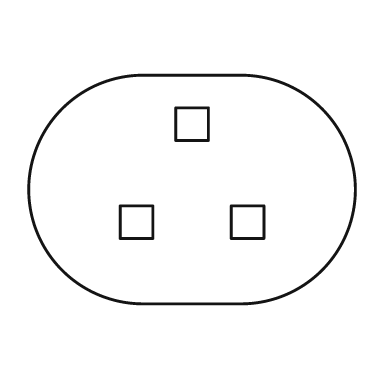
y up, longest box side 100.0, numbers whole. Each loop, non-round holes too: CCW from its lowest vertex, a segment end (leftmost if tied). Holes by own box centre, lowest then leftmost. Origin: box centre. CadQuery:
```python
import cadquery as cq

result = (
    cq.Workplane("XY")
    .moveTo(-15.0, -35.0)
    .lineTo(15.0, -35.0)
    .threePointArc((50.0, 0.0), (15.0, 35.0))
    .lineTo(-15.0, 35.0)
    .threePointArc((-50.0, 0.0), (-15.0, -35.0))
    .close()
    .moveTo(-22.0, -15.0)
    .lineTo(-12.0, -15.0)
    .lineTo(-12.0, -5.0)
    .lineTo(-22.0, -5.0)
    .close()
    .moveTo(12.0, -15.0)
    .lineTo(22.0, -15.0)
    .lineTo(22.0, -5.0)
    .lineTo(12.0, -5.0)
    .close()
    .moveTo(-5.0, 15.0)
    .lineTo(5.0, 15.0)
    .lineTo(5.0, 25.0)
    .lineTo(-5.0, 25.0)
    .close()
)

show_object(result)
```